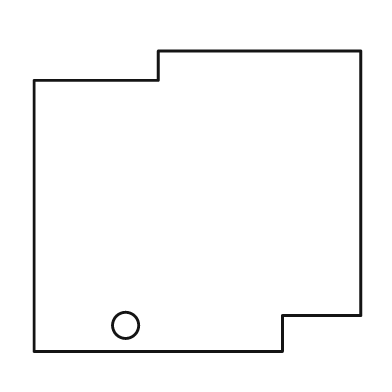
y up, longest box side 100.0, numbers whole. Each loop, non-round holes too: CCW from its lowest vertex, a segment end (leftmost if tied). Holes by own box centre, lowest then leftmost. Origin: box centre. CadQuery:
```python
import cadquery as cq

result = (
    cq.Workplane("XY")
    .moveTo(-50.0, -46.0)
    .lineTo(26.0, -46.0)
    .lineTo(26.0, -35.0)
    .lineTo(50.0, -35.0)
    .lineTo(50.0, 46.0)
    .lineTo(-12.0, 46.0)
    .lineTo(-12.0, 37.0)
    .lineTo(-50.0, 37.0)
    .close()
    .moveTo(-22.0, -38.0)
    .circle(4.0)
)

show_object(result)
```